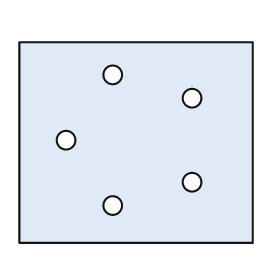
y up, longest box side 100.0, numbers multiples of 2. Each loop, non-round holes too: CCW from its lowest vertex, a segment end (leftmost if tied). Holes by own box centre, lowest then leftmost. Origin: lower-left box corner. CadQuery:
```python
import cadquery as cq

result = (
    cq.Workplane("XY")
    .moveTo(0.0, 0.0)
    .lineTo(100.0, 0.0)
    .lineTo(100.0, 86.0)
    .lineTo(0.0, 86.0)
    .close()
    .moveTo(40.0, 16.0)
    .circle(4.0)
    .moveTo(74.0, 26.0)
    .circle(4.0)
    .moveTo(20.0, 44.0)
    .circle(4.0)
    .moveTo(74.0, 62.0)
    .circle(4.0)
    .moveTo(40.0, 72.0)
    .circle(4.0)
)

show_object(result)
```